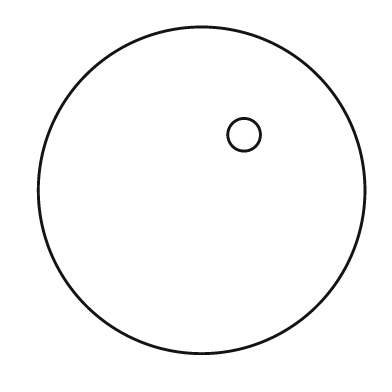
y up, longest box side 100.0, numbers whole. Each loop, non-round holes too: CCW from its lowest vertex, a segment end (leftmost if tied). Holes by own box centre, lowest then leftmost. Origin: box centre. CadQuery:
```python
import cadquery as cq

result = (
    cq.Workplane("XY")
    .moveTo(0.0, 0.0)
    .circle(50.0)
    .moveTo(13.0, 17.0)
    .circle(5.0)
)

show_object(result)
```